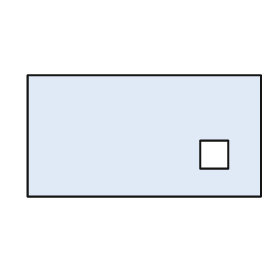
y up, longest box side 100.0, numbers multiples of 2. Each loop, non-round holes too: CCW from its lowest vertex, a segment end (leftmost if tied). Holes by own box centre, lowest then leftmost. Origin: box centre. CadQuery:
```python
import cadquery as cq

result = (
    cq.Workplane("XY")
    .moveTo(-50.0, -26.0)
    .lineTo(50.0, -26.0)
    .lineTo(50.0, 26.0)
    .lineTo(-50.0, 26.0)
    .close()
    .moveTo(24.0, -14.0)
    .lineTo(36.0, -14.0)
    .lineTo(36.0, -2.0)
    .lineTo(24.0, -2.0)
    .close()
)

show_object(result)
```